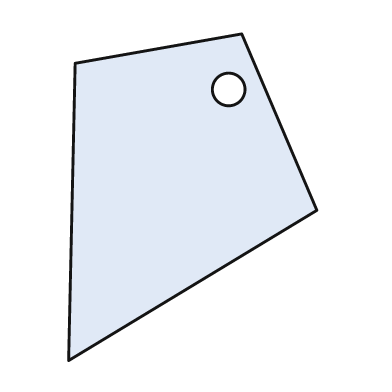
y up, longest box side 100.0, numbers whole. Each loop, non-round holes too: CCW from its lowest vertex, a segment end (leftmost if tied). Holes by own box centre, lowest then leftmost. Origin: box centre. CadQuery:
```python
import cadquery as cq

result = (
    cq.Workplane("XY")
    .moveTo(-38.0, -50.0)
    .lineTo(38.0, -4.0)
    .lineTo(15.0, 50.0)
    .lineTo(-36.0, 41.0)
    .close()
    .moveTo(11.0, 33.0)
    .circle(5.0)
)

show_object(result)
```